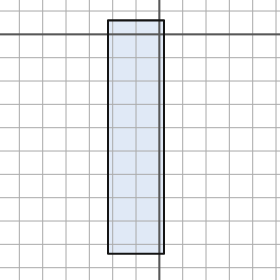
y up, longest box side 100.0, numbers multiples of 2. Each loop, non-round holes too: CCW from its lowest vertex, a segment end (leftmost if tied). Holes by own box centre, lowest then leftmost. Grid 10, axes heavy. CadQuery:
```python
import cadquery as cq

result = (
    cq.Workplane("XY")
    .moveTo(-22.0, -94.0)
    .lineTo(2.0, -94.0)
    .lineTo(2.0, 6.0)
    .lineTo(-22.0, 6.0)
    .close()
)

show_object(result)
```